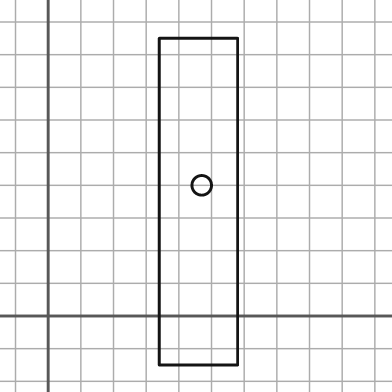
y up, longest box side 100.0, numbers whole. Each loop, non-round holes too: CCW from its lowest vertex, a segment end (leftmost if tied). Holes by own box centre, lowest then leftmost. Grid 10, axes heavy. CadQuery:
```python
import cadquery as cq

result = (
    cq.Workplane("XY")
    .moveTo(34.0, -15.0)
    .lineTo(58.0, -15.0)
    .lineTo(58.0, 85.0)
    .lineTo(34.0, 85.0)
    .close()
    .moveTo(47.0, 40.0)
    .circle(3.0)
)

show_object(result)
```